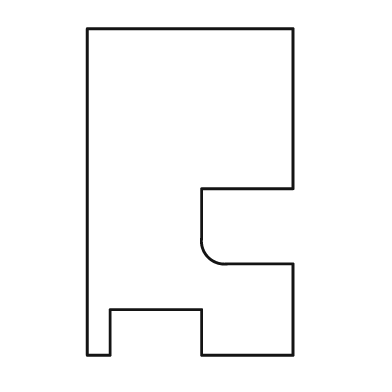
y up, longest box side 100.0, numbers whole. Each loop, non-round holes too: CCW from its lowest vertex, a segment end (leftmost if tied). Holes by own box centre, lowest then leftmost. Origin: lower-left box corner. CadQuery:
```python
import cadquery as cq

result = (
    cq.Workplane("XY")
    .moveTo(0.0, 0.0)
    .lineTo(7.0, 0.0)
    .lineTo(7.0, 14.0)
    .lineTo(35.0, 14.0)
    .lineTo(35.0, 0.0)
    .lineTo(63.0, 0.0)
    .lineTo(63.0, 28.0)
    .lineTo(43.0, 28.0)
    .threePointArc((37.0, 30.0), (35.0, 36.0))
    .lineTo(35.0, 51.0)
    .lineTo(63.0, 51.0)
    .lineTo(63.0, 100.0)
    .lineTo(0.0, 100.0)
    .close()
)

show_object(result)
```